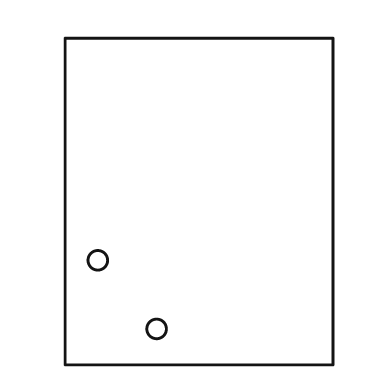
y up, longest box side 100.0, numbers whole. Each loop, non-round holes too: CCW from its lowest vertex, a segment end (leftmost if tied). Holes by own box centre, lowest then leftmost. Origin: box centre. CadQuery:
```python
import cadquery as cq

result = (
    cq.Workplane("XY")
    .moveTo(-41.0, -50.0)
    .lineTo(41.0, -50.0)
    .lineTo(41.0, 50.0)
    .lineTo(-41.0, 50.0)
    .close()
    .moveTo(-13.0, -39.0)
    .circle(3.0)
    .moveTo(-31.0, -18.0)
    .circle(3.0)
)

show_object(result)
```